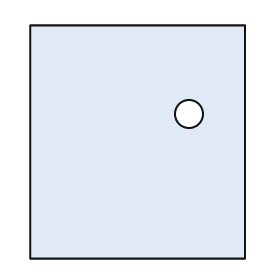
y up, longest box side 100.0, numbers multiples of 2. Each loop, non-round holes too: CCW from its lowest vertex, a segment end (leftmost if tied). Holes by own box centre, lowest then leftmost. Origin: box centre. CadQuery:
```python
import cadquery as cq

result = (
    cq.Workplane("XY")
    .moveTo(-46.0, -50.0)
    .lineTo(46.0, -50.0)
    .lineTo(46.0, 50.0)
    .lineTo(-46.0, 50.0)
    .close()
    .moveTo(22.0, 12.0)
    .circle(6.0)
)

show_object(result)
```